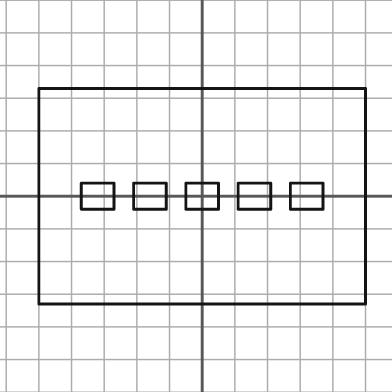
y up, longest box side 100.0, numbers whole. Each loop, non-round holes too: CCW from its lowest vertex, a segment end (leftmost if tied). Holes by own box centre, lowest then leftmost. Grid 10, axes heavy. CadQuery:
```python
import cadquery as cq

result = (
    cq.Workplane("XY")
    .moveTo(-50.0, -33.0)
    .lineTo(50.0, -33.0)
    .lineTo(50.0, 33.0)
    .lineTo(-50.0, 33.0)
    .close()
    .moveTo(-37.0, -4.0)
    .lineTo(-27.0, -4.0)
    .lineTo(-27.0, 4.0)
    .lineTo(-37.0, 4.0)
    .close()
    .moveTo(-21.0, -4.0)
    .lineTo(-11.0, -4.0)
    .lineTo(-11.0, 4.0)
    .lineTo(-21.0, 4.0)
    .close()
    .moveTo(-5.0, -4.0)
    .lineTo(5.0, -4.0)
    .lineTo(5.0, 4.0)
    .lineTo(-5.0, 4.0)
    .close()
    .moveTo(11.0, -4.0)
    .lineTo(21.0, -4.0)
    .lineTo(21.0, 4.0)
    .lineTo(11.0, 4.0)
    .close()
    .moveTo(27.0, -4.0)
    .lineTo(37.0, -4.0)
    .lineTo(37.0, 4.0)
    .lineTo(27.0, 4.0)
    .close()
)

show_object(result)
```